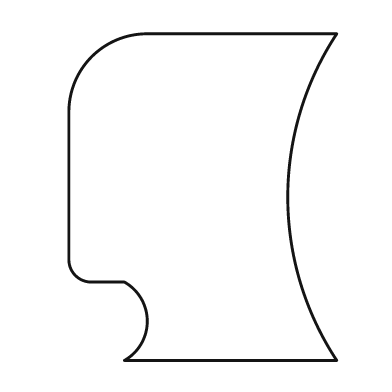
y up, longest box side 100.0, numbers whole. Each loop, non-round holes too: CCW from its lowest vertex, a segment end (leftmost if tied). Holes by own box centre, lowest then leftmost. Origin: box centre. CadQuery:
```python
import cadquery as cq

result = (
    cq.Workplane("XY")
    .moveTo(-24.0, -50.0)
    .lineTo(41.0, -50.0)
    .threePointArc((26.0, 0.0), (41.0, 50.0))
    .lineTo(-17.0, 50.0)
    .threePointArc((-34.0, 43.0), (-41.0, 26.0))
    .lineTo(-41.0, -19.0)
    .threePointArc((-39.0, -24.0), (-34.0, -26.0))
    .lineTo(-24.0, -26.0)
    .threePointArc((-17.0, -38.0), (-24.0, -50.0))
    .close()
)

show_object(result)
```